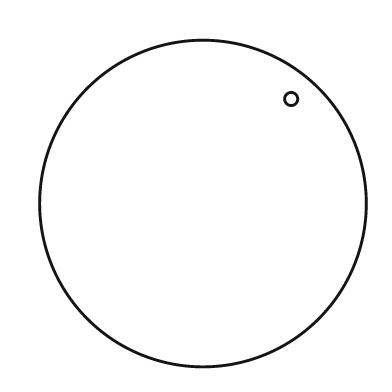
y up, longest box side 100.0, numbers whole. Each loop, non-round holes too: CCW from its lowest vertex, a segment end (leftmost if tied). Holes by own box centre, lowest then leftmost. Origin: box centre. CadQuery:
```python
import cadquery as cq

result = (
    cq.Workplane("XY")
    .moveTo(0.0, 0.0)
    .circle(50.0)
    .moveTo(27.0, 32.0)
    .circle(2.0)
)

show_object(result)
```